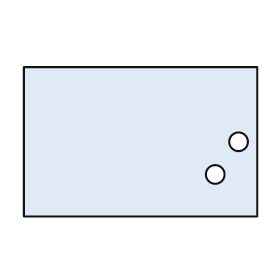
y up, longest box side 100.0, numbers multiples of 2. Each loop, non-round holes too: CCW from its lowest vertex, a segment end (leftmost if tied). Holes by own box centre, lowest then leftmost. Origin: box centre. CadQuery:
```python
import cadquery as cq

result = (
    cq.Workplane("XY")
    .moveTo(-50.0, -32.0)
    .lineTo(50.0, -32.0)
    .lineTo(50.0, 32.0)
    .lineTo(-50.0, 32.0)
    .close()
    .moveTo(32.0, -14.0)
    .circle(4.0)
    .moveTo(42.0, 0.0)
    .circle(4.0)
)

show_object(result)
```